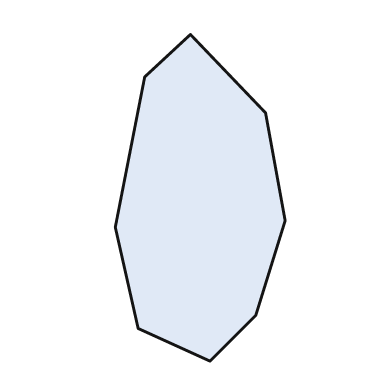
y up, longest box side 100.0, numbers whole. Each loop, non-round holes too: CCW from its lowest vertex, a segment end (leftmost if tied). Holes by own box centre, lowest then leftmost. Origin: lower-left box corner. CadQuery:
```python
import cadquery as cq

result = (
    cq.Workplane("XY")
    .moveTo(29.0, 0.0)
    .lineTo(43.0, 14.0)
    .lineTo(52.0, 43.0)
    .lineTo(46.0, 76.0)
    .lineTo(23.0, 100.0)
    .lineTo(9.0, 87.0)
    .lineTo(0.0, 41.0)
    .lineTo(7.0, 10.0)
    .close()
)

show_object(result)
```